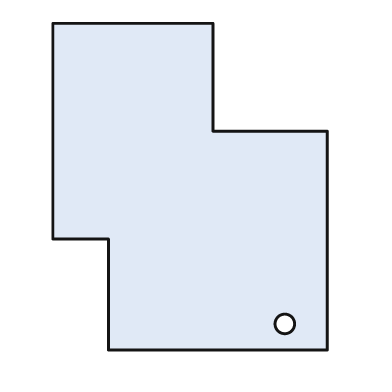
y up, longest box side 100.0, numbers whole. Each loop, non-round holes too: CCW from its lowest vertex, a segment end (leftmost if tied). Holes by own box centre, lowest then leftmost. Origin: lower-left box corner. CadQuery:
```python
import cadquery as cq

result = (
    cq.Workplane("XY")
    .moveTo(17.0, 0.0)
    .lineTo(84.0, 0.0)
    .lineTo(84.0, 67.0)
    .lineTo(49.0, 67.0)
    .lineTo(49.0, 100.0)
    .lineTo(0.0, 100.0)
    .lineTo(0.0, 34.0)
    .lineTo(17.0, 34.0)
    .close()
    .moveTo(71.0, 8.0)
    .circle(3.0)
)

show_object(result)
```